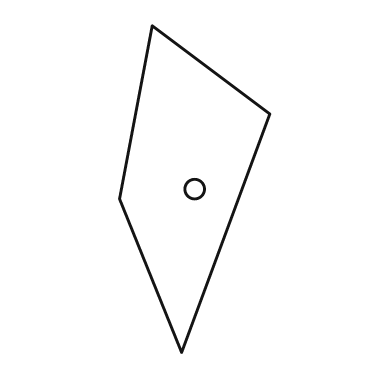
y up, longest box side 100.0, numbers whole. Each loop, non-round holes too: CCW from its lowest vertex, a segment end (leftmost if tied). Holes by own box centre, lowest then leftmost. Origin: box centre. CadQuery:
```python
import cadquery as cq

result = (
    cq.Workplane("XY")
    .moveTo(-4.0, -50.0)
    .lineTo(23.0, 23.0)
    .lineTo(-13.0, 50.0)
    .lineTo(-23.0, -3.0)
    .close()
    .moveTo(0.0, 0.0)
    .circle(3.0)
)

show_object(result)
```